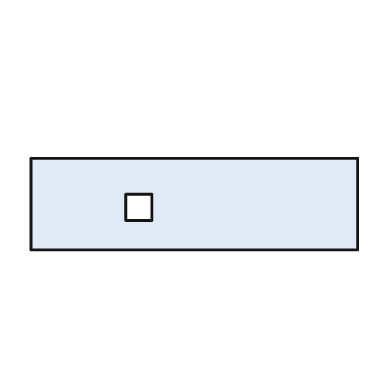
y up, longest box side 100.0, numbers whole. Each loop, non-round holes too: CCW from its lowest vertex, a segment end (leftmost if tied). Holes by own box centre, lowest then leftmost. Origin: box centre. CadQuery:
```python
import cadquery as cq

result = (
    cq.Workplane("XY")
    .moveTo(-50.0, -14.0)
    .lineTo(50.0, -14.0)
    .lineTo(50.0, 14.0)
    .lineTo(-50.0, 14.0)
    .close()
    .moveTo(-21.0, -5.0)
    .lineTo(-13.0, -5.0)
    .lineTo(-13.0, 3.0)
    .lineTo(-21.0, 3.0)
    .close()
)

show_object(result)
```